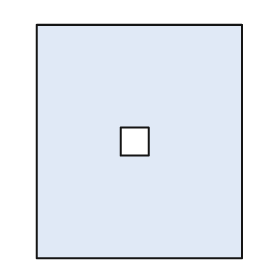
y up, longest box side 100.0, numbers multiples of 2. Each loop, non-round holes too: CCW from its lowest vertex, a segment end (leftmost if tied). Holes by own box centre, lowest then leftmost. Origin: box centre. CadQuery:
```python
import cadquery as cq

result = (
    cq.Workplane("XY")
    .moveTo(-44.0, -50.0)
    .lineTo(44.0, -50.0)
    .lineTo(44.0, 50.0)
    .lineTo(-44.0, 50.0)
    .close()
    .moveTo(-8.0, -6.0)
    .lineTo(4.0, -6.0)
    .lineTo(4.0, 6.0)
    .lineTo(-8.0, 6.0)
    .close()
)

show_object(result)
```